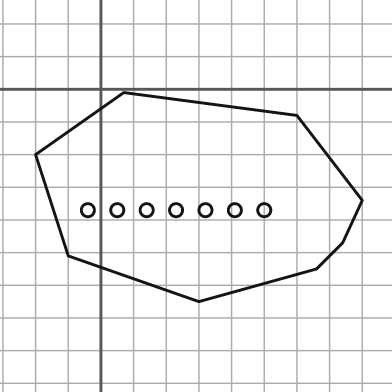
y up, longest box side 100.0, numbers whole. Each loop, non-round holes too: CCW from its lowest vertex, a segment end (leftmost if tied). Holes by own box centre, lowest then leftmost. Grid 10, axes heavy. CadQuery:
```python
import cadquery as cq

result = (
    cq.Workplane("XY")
    .moveTo(30.0, -65.0)
    .lineTo(66.0, -55.0)
    .lineTo(74.0, -47.0)
    .lineTo(80.0, -34.0)
    .lineTo(60.0, -8.0)
    .lineTo(7.0, -1.0)
    .lineTo(-20.0, -20.0)
    .lineTo(-10.0, -51.0)
    .close()
    .moveTo(-4.0, -37.0)
    .circle(2.0)
    .moveTo(5.0, -37.0)
    .circle(2.0)
    .moveTo(14.0, -37.0)
    .circle(2.0)
    .moveTo(23.0, -37.0)
    .circle(2.0)
    .moveTo(32.0, -37.0)
    .circle(2.0)
    .moveTo(41.0, -37.0)
    .circle(2.0)
    .moveTo(50.0, -37.0)
    .circle(2.0)
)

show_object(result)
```